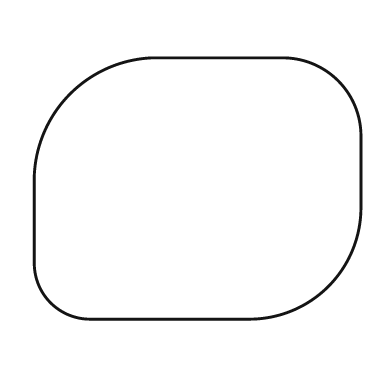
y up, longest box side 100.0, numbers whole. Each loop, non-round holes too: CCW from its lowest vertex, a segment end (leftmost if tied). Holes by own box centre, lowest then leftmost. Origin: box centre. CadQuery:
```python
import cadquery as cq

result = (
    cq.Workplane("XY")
    .moveTo(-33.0, -40.0)
    .lineTo(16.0, -40.0)
    .threePointArc((40.0, -30.0), (50.0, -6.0))
    .lineTo(50.0, 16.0)
    .threePointArc((43.0, 33.0), (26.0, 40.0))
    .lineTo(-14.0, 40.0)
    .threePointArc((-39.0, 29.0), (-50.0, 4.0))
    .lineTo(-50.0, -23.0)
    .threePointArc((-45.0, -35.0), (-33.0, -40.0))
    .close()
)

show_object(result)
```